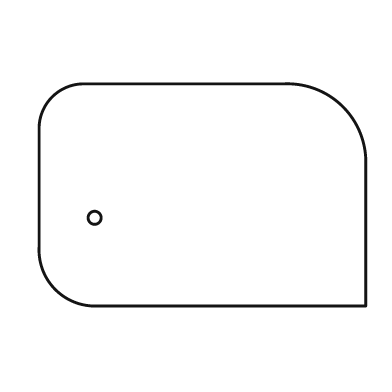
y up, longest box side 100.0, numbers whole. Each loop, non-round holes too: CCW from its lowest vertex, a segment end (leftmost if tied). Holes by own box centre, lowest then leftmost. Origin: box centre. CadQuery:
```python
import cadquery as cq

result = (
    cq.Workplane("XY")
    .moveTo(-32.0, -34.0)
    .lineTo(50.0, -34.0)
    .lineTo(50.0, 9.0)
    .threePointArc((43.0, 27.0), (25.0, 34.0))
    .lineTo(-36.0, 34.0)
    .threePointArc((-46.0, 30.0), (-50.0, 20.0))
    .lineTo(-50.0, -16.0)
    .threePointArc((-45.0, -29.0), (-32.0, -34.0))
    .close()
    .moveTo(-33.0, -7.0)
    .circle(2.0)
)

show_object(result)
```